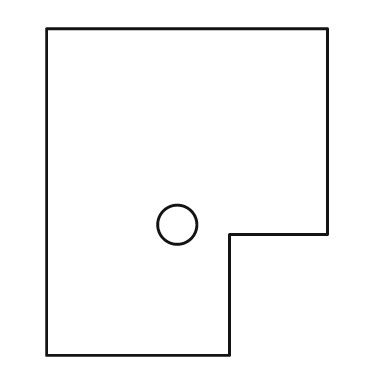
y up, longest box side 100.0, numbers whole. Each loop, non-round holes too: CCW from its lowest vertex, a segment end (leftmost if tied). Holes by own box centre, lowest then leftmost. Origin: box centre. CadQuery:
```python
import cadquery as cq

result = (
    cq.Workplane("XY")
    .moveTo(-43.0, -50.0)
    .lineTo(13.0, -50.0)
    .lineTo(13.0, -13.0)
    .lineTo(43.0, -13.0)
    .lineTo(43.0, 50.0)
    .lineTo(-43.0, 50.0)
    .close()
    .moveTo(-3.0, -10.0)
    .circle(6.0)
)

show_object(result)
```